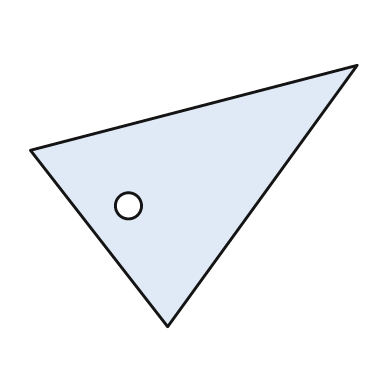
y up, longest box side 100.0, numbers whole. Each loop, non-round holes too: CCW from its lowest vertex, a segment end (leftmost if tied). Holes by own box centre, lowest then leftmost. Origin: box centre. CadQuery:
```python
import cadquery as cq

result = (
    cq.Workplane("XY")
    .moveTo(-8.0, -40.0)
    .lineTo(50.0, 40.0)
    .lineTo(-50.0, 14.0)
    .close()
    .moveTo(-20.0, -3.0)
    .circle(4.0)
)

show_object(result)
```